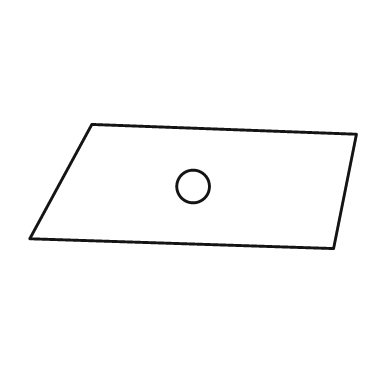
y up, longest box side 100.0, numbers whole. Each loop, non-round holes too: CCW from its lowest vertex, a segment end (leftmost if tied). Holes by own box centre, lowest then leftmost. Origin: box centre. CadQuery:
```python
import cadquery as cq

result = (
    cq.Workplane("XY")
    .moveTo(43.0, -19.0)
    .lineTo(50.0, 16.0)
    .lineTo(-31.0, 19.0)
    .lineTo(-50.0, -16.0)
    .close()
    .moveTo(0.0, 0.0)
    .circle(5.0)
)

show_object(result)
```